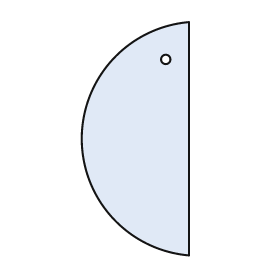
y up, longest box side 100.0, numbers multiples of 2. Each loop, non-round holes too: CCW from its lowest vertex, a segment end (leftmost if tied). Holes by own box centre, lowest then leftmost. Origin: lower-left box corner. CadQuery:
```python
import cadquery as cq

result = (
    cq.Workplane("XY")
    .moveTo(46.0, 0.0)
    .lineTo(46.0, 100.0)
    .threePointArc((0.0, 50.0), (46.0, 0.0))
    .close()
    .moveTo(36.0, 84.0)
    .circle(2.0)
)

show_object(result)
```